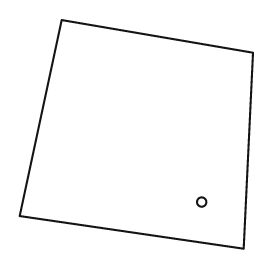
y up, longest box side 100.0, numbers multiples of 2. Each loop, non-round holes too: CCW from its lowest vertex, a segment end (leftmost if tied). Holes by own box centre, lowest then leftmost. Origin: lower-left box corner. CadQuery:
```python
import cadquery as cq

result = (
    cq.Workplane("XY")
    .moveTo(96.0, 0.0)
    .lineTo(100.0, 84.0)
    .lineTo(18.0, 98.0)
    .lineTo(0.0, 14.0)
    .close()
    .moveTo(78.0, 20.0)
    .circle(2.0)
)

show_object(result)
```